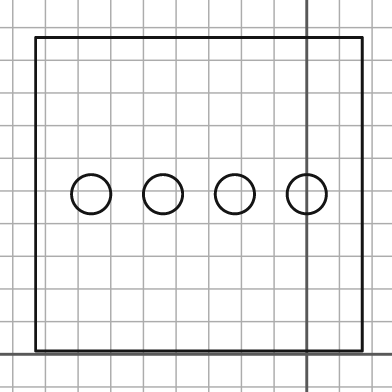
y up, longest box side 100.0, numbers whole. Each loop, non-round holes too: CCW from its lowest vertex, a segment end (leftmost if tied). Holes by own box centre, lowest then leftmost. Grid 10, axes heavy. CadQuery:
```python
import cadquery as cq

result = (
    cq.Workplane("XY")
    .moveTo(-83.0, 1.0)
    .lineTo(17.0, 1.0)
    .lineTo(17.0, 97.0)
    .lineTo(-83.0, 97.0)
    .close()
    .moveTo(-66.0, 49.0)
    .circle(6.0)
    .moveTo(-44.0, 49.0)
    .circle(6.0)
    .moveTo(-22.0, 49.0)
    .circle(6.0)
    .moveTo(0.0, 49.0)
    .circle(6.0)
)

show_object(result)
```